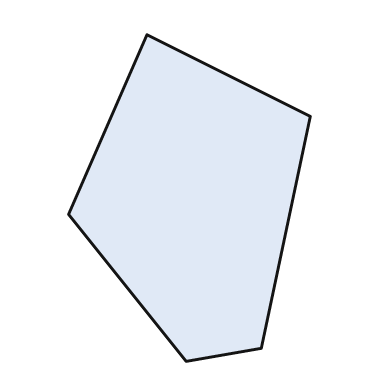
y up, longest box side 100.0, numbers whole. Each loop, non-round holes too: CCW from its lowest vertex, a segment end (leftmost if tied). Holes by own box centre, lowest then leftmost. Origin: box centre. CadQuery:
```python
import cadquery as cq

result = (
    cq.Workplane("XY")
    .moveTo(-1.0, -50.0)
    .lineTo(22.0, -46.0)
    .lineTo(37.0, 25.0)
    .lineTo(-13.0, 50.0)
    .lineTo(-37.0, -5.0)
    .close()
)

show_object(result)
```